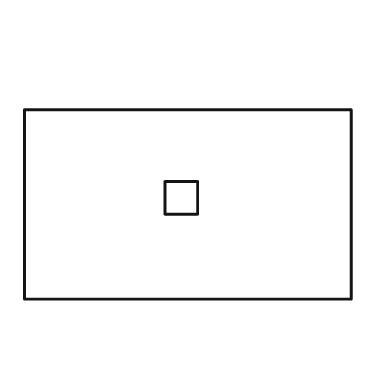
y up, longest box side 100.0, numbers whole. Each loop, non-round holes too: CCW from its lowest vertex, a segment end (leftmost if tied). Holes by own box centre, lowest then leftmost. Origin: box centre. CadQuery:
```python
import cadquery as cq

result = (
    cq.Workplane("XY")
    .moveTo(-50.0, -29.0)
    .lineTo(50.0, -29.0)
    .lineTo(50.0, 29.0)
    .lineTo(-50.0, 29.0)
    .close()
    .moveTo(-7.0, -3.0)
    .lineTo(3.0, -3.0)
    .lineTo(3.0, 7.0)
    .lineTo(-7.0, 7.0)
    .close()
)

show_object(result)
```